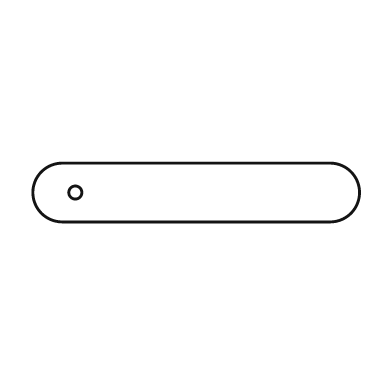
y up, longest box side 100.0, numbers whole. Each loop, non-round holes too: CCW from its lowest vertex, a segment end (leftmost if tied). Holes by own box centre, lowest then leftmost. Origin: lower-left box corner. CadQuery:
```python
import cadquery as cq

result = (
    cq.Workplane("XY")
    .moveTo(9.0, 0.0)
    .lineTo(91.0, 0.0)
    .threePointArc((100.0, 9.0), (91.0, 18.0))
    .lineTo(9.0, 18.0)
    .threePointArc((0.0, 9.0), (9.0, 0.0))
    .close()
    .moveTo(13.0, 9.0)
    .circle(2.0)
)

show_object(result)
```